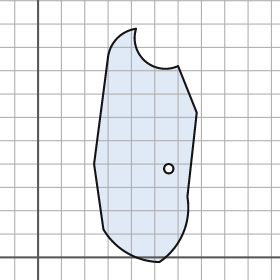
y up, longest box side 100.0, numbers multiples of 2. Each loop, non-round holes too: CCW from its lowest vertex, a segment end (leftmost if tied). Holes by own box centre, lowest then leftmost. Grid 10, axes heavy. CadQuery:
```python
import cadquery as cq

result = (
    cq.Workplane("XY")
    .moveTo(52.0, -2.0)
    .threePointArc((62.0, 10.0), (64.0, 26.0))
    .lineTo(68.0, 62.0)
    .lineTo(60.0, 82.0)
    .threePointArc((46.0, 84.0), (42.0, 98.0))
    .threePointArc((34.0, 94.0), (30.0, 86.0))
    .lineTo(24.0, 40.0)
    .lineTo(28.0, 12.0)
    .threePointArc((38.0, 2.0), (52.0, -2.0))
    .close()
    .moveTo(56.0, 38.0)
    .circle(2.0)
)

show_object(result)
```